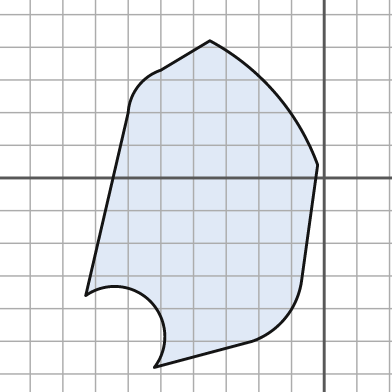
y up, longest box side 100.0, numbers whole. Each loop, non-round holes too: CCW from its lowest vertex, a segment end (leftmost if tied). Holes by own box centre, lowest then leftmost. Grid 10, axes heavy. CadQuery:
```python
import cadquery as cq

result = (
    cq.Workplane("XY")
    .moveTo(-52.0, -58.0)
    .lineTo(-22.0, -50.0)
    .threePointArc((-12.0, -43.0), (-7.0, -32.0))
    .lineTo(-2.0, 4.0)
    .threePointArc((-15.0, 26.0), (-35.0, 42.0))
    .lineTo(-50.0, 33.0)
    .threePointArc((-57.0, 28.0), (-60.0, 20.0))
    .lineTo(-73.0, -36.0)
    .threePointArc((-53.0, -38.0), (-52.0, -58.0))
    .close()
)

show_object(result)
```